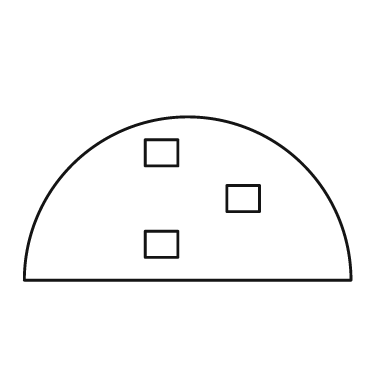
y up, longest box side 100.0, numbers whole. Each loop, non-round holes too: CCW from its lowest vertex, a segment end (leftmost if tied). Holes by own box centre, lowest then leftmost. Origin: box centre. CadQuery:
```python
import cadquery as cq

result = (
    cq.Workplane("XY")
    .moveTo(-50.0, -25.0)
    .lineTo(50.0, -25.0)
    .threePointArc((0.0, 25.0), (-50.0, -25.0))
    .close()
    .moveTo(-13.0, -18.0)
    .lineTo(-3.0, -18.0)
    .lineTo(-3.0, -10.0)
    .lineTo(-13.0, -10.0)
    .close()
    .moveTo(12.0, -4.0)
    .lineTo(22.0, -4.0)
    .lineTo(22.0, 4.0)
    .lineTo(12.0, 4.0)
    .close()
    .moveTo(-13.0, 10.0)
    .lineTo(-3.0, 10.0)
    .lineTo(-3.0, 18.0)
    .lineTo(-13.0, 18.0)
    .close()
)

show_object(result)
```